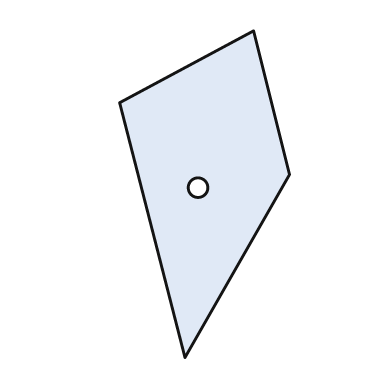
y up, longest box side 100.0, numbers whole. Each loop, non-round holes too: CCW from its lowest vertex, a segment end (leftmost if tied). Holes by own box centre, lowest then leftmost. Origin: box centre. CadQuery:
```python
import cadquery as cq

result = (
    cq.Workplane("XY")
    .moveTo(-6.0, -50.0)
    .lineTo(26.0, 6.0)
    .lineTo(15.0, 50.0)
    .lineTo(-26.0, 28.0)
    .close()
    .moveTo(-2.0, 2.0)
    .circle(3.0)
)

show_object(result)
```